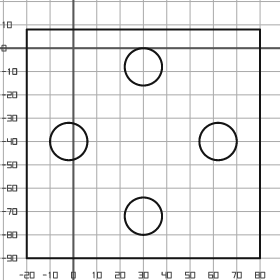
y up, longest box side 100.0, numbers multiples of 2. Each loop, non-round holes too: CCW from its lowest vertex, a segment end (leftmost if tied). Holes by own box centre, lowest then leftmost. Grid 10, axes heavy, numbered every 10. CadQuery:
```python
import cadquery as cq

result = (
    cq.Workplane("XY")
    .moveTo(-20.0, -90.0)
    .lineTo(80.0, -90.0)
    .lineTo(80.0, 8.0)
    .lineTo(-20.0, 8.0)
    .close()
    .moveTo(30.0, -72.0)
    .circle(8.0)
    .moveTo(-2.0, -40.0)
    .circle(8.0)
    .moveTo(62.0, -40.0)
    .circle(8.0)
    .moveTo(30.0, -8.0)
    .circle(8.0)
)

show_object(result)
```